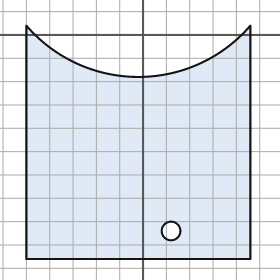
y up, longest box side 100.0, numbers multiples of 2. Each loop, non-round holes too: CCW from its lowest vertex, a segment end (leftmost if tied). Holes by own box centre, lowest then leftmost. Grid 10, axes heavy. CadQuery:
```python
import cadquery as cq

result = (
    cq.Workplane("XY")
    .moveTo(-50.0, -96.0)
    .lineTo(46.0, -96.0)
    .lineTo(46.0, 4.0)
    .threePointArc((-2.0, -18.0), (-50.0, 4.0))
    .close()
    .moveTo(12.0, -84.0)
    .circle(4.0)
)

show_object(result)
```